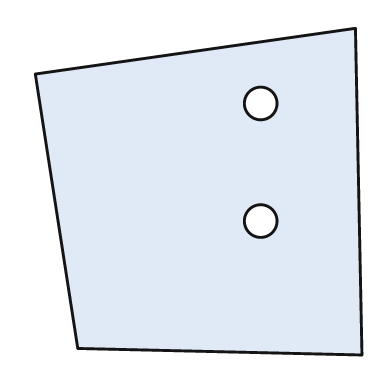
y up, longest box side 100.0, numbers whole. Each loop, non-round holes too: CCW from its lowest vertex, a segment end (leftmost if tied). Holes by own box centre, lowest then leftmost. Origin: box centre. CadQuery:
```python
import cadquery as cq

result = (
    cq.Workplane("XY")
    .moveTo(50.0, -50.0)
    .lineTo(48.0, 50.0)
    .lineTo(-50.0, 36.0)
    .lineTo(-37.0, -48.0)
    .close()
    .moveTo(19.0, -9.0)
    .circle(5.0)
    .moveTo(19.0, 27.0)
    .circle(5.0)
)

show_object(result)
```